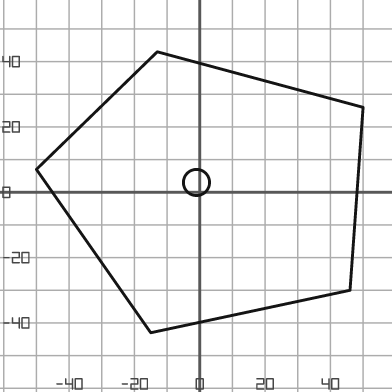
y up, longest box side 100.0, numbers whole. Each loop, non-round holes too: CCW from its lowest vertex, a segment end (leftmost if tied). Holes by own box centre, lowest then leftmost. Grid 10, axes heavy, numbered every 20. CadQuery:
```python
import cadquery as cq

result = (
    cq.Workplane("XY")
    .moveTo(-15.0, -43.0)
    .lineTo(46.0, -30.0)
    .lineTo(50.0, 26.0)
    .lineTo(-13.0, 43.0)
    .lineTo(-50.0, 7.0)
    .close()
    .moveTo(-1.0, 3.0)
    .circle(4.0)
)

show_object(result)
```